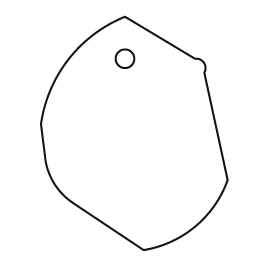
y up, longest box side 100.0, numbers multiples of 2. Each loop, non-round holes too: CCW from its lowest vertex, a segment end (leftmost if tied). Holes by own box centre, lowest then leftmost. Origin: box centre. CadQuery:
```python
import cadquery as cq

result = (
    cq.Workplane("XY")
    .moveTo(4.0, -50.0)
    .threePointArc((26.0, -40.0), (40.0, -20.0))
    .lineTo(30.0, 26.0)
    .threePointArc((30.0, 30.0), (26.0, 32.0))
    .lineTo(-4.0, 50.0)
    .threePointArc((-28.0, 32.0), (-40.0, 4.0))
    .lineTo(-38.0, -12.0)
    .threePointArc((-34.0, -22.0), (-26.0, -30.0))
    .close()
    .moveTo(-4.0, 32.0)
    .circle(4.0)
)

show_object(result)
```